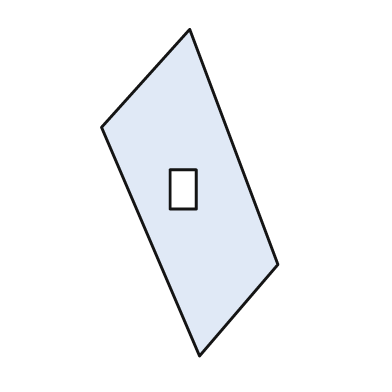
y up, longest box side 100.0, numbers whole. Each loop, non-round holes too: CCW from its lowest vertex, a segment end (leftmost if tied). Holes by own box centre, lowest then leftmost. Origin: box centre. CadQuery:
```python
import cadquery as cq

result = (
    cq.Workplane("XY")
    .moveTo(3.0, -50.0)
    .lineTo(27.0, -22.0)
    .lineTo(0.0, 50.0)
    .lineTo(-27.0, 20.0)
    .close()
    .moveTo(-6.0, -5.0)
    .lineTo(2.0, -5.0)
    .lineTo(2.0, 7.0)
    .lineTo(-6.0, 7.0)
    .close()
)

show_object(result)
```